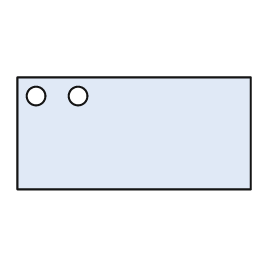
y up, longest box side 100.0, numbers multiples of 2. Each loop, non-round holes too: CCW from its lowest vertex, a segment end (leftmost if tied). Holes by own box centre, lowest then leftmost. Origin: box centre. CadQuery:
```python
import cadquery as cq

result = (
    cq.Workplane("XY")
    .moveTo(-50.0, -24.0)
    .lineTo(50.0, -24.0)
    .lineTo(50.0, 24.0)
    .lineTo(-50.0, 24.0)
    .close()
    .moveTo(-42.0, 16.0)
    .circle(4.0)
    .moveTo(-24.0, 16.0)
    .circle(4.0)
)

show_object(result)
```